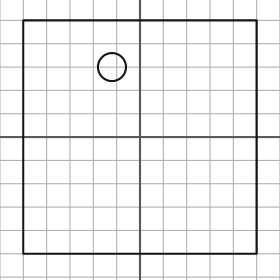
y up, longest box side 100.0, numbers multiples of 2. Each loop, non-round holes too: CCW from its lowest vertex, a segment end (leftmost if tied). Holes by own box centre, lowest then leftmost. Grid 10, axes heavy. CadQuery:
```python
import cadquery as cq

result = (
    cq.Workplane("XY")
    .moveTo(-50.0, -50.0)
    .lineTo(50.0, -50.0)
    .lineTo(50.0, 50.0)
    .lineTo(-50.0, 50.0)
    .close()
    .moveTo(-12.0, 30.0)
    .circle(6.0)
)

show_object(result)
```